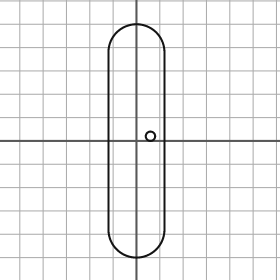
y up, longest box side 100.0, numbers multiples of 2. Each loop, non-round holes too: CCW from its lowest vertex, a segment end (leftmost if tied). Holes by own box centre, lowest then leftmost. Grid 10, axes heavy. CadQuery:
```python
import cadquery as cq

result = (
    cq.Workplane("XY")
    .moveTo(-12.0, -38.0)
    .threePointArc((0.0, -50.0), (12.0, -38.0))
    .lineTo(12.0, 38.0)
    .threePointArc((0.0, 50.0), (-12.0, 38.0))
    .close()
    .moveTo(6.0, 2.0)
    .circle(2.0)
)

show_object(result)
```